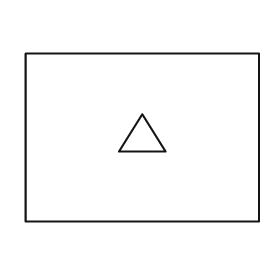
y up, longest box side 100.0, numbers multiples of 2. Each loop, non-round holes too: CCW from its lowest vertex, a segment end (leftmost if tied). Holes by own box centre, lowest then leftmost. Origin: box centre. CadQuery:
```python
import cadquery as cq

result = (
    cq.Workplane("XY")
    .moveTo(-50.0, -36.0)
    .lineTo(50.0, -36.0)
    .lineTo(50.0, 36.0)
    .lineTo(-50.0, 36.0)
    .close()
    .moveTo(-10.0, -6.0)
    .lineTo(10.0, -6.0)
    .lineTo(0.0, 10.0)
    .close()
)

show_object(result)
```